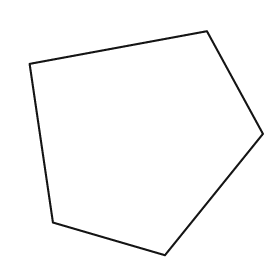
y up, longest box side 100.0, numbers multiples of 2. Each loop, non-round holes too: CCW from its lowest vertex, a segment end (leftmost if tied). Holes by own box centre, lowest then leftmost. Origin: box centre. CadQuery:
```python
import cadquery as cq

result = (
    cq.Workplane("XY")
    .moveTo(8.0, -48.0)
    .lineTo(50.0, 4.0)
    .lineTo(26.0, 48.0)
    .lineTo(-50.0, 34.0)
    .lineTo(-40.0, -34.0)
    .close()
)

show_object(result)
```